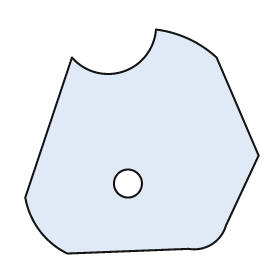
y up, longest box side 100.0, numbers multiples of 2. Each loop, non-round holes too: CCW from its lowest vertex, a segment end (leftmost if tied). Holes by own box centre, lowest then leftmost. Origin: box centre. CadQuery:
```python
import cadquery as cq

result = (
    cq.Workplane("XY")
    .moveTo(-32.0, -48.0)
    .lineTo(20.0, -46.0)
    .threePointArc((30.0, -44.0), (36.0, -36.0))
    .lineTo(50.0, -6.0)
    .lineTo(32.0, 36.0)
    .threePointArc((20.0, 44.0), (6.0, 48.0))
    .threePointArc((-8.0, 30.0), (-30.0, 36.0))
    .lineTo(-50.0, -24.0)
    .threePointArc((-44.0, -38.0), (-32.0, -48.0))
    .close()
    .moveTo(-6.0, -18.0)
    .circle(6.0)
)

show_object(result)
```